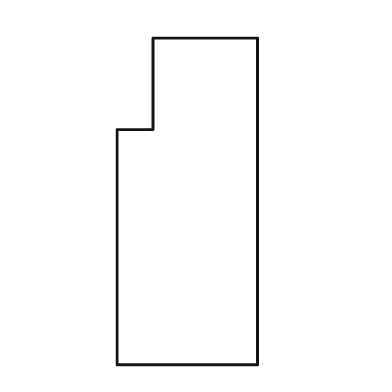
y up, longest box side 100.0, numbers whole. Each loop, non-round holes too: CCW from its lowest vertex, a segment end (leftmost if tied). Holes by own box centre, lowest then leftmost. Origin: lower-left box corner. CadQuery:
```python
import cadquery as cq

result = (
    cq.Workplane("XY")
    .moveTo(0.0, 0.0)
    .lineTo(43.0, 0.0)
    .lineTo(43.0, 100.0)
    .lineTo(11.0, 100.0)
    .lineTo(11.0, 72.0)
    .lineTo(0.0, 72.0)
    .close()
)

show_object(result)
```